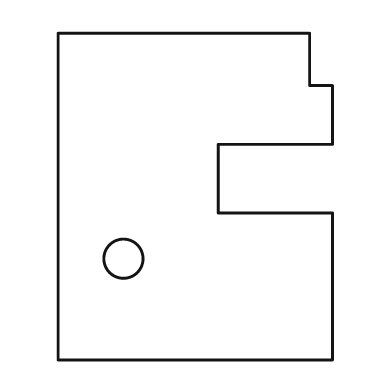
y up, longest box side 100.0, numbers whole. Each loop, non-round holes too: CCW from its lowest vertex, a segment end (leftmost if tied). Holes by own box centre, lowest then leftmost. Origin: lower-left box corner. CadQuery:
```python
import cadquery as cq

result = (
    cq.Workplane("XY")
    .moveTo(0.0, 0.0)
    .lineTo(84.0, 0.0)
    .lineTo(84.0, 45.0)
    .lineTo(49.0, 45.0)
    .lineTo(49.0, 66.0)
    .lineTo(84.0, 66.0)
    .lineTo(84.0, 84.0)
    .lineTo(77.0, 84.0)
    .lineTo(77.0, 100.0)
    .lineTo(0.0, 100.0)
    .close()
    .moveTo(20.0, 31.0)
    .circle(6.0)
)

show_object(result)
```